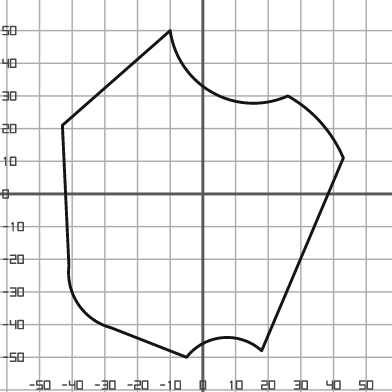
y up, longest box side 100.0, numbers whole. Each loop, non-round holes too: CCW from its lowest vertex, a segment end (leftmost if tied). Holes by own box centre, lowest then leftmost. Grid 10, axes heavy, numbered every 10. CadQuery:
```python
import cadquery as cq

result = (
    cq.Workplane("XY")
    .moveTo(-5.0, -50.0)
    .threePointArc((6.0, -44.0), (18.0, -48.0))
    .lineTo(43.0, 11.0)
    .threePointArc((36.0, 22.0), (26.0, 30.0))
    .threePointArc((3.0, 31.0), (-10.0, 50.0))
    .lineTo(-43.0, 21.0)
    .lineTo(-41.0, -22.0)
    .threePointArc((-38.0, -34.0), (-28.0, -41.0))
    .close()
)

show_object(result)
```